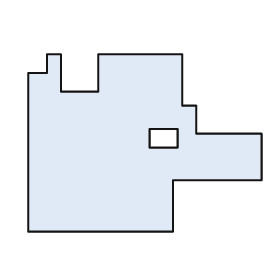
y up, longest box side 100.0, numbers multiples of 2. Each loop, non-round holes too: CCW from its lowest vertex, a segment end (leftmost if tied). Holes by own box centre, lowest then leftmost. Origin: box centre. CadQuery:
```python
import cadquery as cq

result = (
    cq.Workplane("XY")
    .moveTo(-50.0, -38.0)
    .lineTo(12.0, -38.0)
    .lineTo(12.0, -16.0)
    .lineTo(50.0, -16.0)
    .lineTo(50.0, 4.0)
    .lineTo(22.0, 4.0)
    .lineTo(22.0, 16.0)
    .lineTo(16.0, 16.0)
    .lineTo(16.0, 38.0)
    .lineTo(-20.0, 38.0)
    .lineTo(-20.0, 22.0)
    .lineTo(-36.0, 22.0)
    .lineTo(-36.0, 38.0)
    .lineTo(-42.0, 38.0)
    .lineTo(-42.0, 30.0)
    .lineTo(-50.0, 30.0)
    .close()
    .moveTo(2.0, -2.0)
    .lineTo(14.0, -2.0)
    .lineTo(14.0, 6.0)
    .lineTo(2.0, 6.0)
    .close()
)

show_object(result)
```